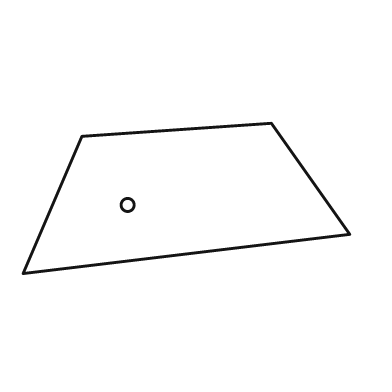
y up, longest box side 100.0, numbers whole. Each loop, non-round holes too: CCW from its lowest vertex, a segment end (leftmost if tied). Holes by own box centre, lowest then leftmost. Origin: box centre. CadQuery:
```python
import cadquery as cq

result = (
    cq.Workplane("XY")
    .moveTo(-50.0, -23.0)
    .lineTo(50.0, -11.0)
    .lineTo(26.0, 23.0)
    .lineTo(-32.0, 19.0)
    .close()
    .moveTo(-18.0, -2.0)
    .circle(2.0)
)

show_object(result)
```